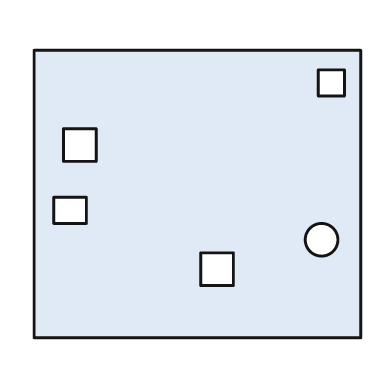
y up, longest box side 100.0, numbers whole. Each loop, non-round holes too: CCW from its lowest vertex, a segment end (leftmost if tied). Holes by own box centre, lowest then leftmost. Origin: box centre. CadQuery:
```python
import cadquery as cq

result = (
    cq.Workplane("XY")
    .moveTo(-50.0, -44.0)
    .lineTo(50.0, -44.0)
    .lineTo(50.0, 44.0)
    .lineTo(-50.0, 44.0)
    .close()
    .moveTo(1.0, -28.0)
    .lineTo(11.0, -28.0)
    .lineTo(11.0, -18.0)
    .lineTo(1.0, -18.0)
    .close()
    .moveTo(38.0, -14.0)
    .circle(5.0)
    .moveTo(-44.0, -9.0)
    .lineTo(-34.0, -9.0)
    .lineTo(-34.0, -1.0)
    .lineTo(-44.0, -1.0)
    .close()
    .moveTo(-41.0, 10.0)
    .lineTo(-31.0, 10.0)
    .lineTo(-31.0, 20.0)
    .lineTo(-41.0, 20.0)
    .close()
    .moveTo(37.0, 30.0)
    .lineTo(45.0, 30.0)
    .lineTo(45.0, 38.0)
    .lineTo(37.0, 38.0)
    .close()
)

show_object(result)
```